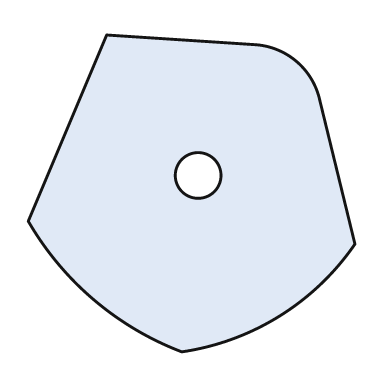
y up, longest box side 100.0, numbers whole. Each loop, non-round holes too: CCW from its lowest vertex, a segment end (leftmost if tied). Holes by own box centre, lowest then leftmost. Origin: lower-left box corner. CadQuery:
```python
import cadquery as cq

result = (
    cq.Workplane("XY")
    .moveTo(47.0, 0.0)
    .threePointArc((77.0, 11.0), (100.0, 33.0))
    .lineTo(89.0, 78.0)
    .threePointArc((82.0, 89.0), (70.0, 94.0))
    .lineTo(24.0, 97.0)
    .lineTo(0.0, 40.0)
    .threePointArc((20.0, 16.0), (47.0, 0.0))
    .close()
    .moveTo(52.0, 54.0)
    .circle(7.0)
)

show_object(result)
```